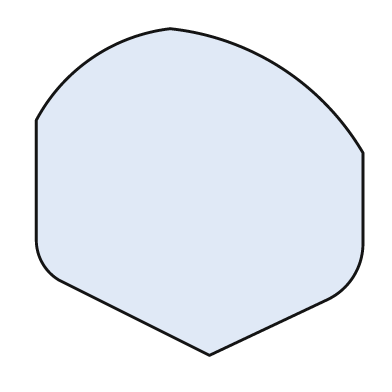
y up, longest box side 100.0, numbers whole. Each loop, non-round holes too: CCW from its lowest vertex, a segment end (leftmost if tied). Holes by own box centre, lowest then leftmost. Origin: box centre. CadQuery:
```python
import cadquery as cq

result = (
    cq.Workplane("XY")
    .moveTo(3.0, -50.0)
    .lineTo(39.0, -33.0)
    .threePointArc((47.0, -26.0), (50.0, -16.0))
    .lineTo(50.0, 12.0)
    .threePointArc((25.0, 38.0), (-9.0, 50.0))
    .threePointArc((-33.0, 41.0), (-50.0, 22.0))
    .lineTo(-50.0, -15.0)
    .threePointArc((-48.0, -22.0), (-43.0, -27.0))
    .close()
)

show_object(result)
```